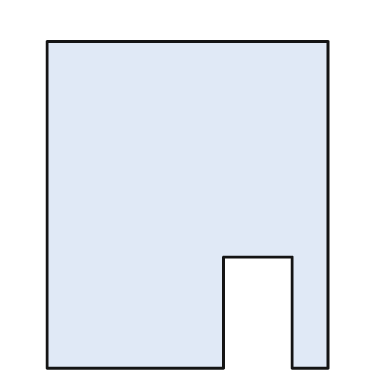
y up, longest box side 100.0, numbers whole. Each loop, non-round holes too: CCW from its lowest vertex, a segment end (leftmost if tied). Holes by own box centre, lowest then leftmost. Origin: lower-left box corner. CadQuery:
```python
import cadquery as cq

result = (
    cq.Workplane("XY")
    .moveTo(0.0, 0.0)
    .lineTo(54.0, 0.0)
    .lineTo(54.0, 34.0)
    .lineTo(75.0, 34.0)
    .lineTo(75.0, 0.0)
    .lineTo(86.0, 0.0)
    .lineTo(86.0, 100.0)
    .lineTo(0.0, 100.0)
    .close()
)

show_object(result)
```